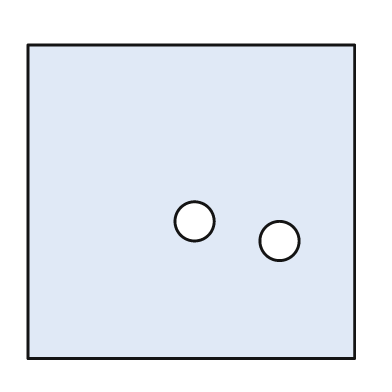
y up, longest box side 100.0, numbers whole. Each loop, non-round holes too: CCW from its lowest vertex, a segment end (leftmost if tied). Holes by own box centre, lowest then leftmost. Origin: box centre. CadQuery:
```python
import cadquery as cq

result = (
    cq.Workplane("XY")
    .moveTo(-50.0, -48.0)
    .lineTo(50.0, -48.0)
    .lineTo(50.0, 48.0)
    .lineTo(-50.0, 48.0)
    .close()
    .moveTo(27.0, -12.0)
    .circle(6.0)
    .moveTo(1.0, -6.0)
    .circle(6.0)
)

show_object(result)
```